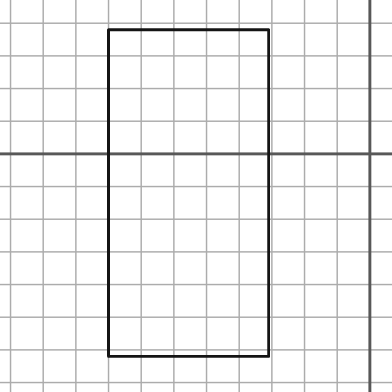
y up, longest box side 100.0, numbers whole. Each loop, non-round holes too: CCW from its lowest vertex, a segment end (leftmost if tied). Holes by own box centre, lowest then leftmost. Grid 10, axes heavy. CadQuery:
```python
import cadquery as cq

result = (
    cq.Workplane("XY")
    .moveTo(-80.0, -62.0)
    .lineTo(-31.0, -62.0)
    .lineTo(-31.0, 38.0)
    .lineTo(-80.0, 38.0)
    .close()
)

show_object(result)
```